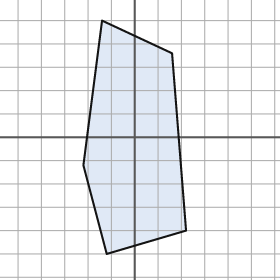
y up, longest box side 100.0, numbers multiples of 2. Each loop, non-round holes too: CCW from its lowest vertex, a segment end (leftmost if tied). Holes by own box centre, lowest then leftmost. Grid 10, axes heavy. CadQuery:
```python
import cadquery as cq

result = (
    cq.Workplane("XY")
    .moveTo(-12.0, -50.0)
    .lineTo(22.0, -40.0)
    .lineTo(16.0, 36.0)
    .lineTo(-14.0, 50.0)
    .lineTo(-22.0, -12.0)
    .close()
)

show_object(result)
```